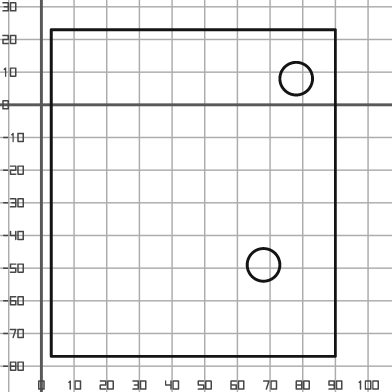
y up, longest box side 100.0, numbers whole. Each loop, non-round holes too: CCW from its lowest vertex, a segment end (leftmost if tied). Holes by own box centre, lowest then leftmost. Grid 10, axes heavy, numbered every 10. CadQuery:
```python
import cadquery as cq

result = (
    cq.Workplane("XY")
    .moveTo(3.0, -77.0)
    .lineTo(90.0, -77.0)
    .lineTo(90.0, 23.0)
    .lineTo(3.0, 23.0)
    .close()
    .moveTo(68.0, -49.0)
    .circle(5.0)
    .moveTo(78.0, 8.0)
    .circle(5.0)
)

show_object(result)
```